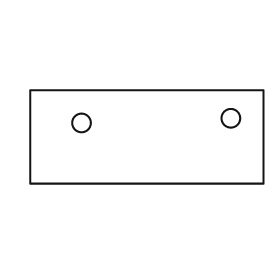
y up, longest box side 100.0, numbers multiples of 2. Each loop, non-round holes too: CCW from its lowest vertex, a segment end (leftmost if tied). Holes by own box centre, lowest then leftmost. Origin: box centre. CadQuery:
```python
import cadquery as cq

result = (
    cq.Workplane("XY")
    .moveTo(-50.0, -20.0)
    .lineTo(50.0, -20.0)
    .lineTo(50.0, 20.0)
    .lineTo(-50.0, 20.0)
    .close()
    .moveTo(-28.0, 6.0)
    .circle(4.0)
    .moveTo(36.0, 8.0)
    .circle(4.0)
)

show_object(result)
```